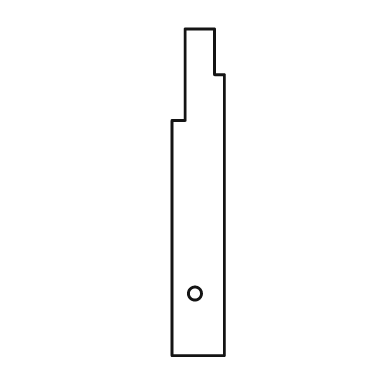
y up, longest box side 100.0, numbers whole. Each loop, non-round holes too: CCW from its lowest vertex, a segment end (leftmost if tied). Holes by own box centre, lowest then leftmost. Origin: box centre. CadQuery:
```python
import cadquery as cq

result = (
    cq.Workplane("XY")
    .moveTo(-8.0, -50.0)
    .lineTo(8.0, -50.0)
    .lineTo(8.0, 36.0)
    .lineTo(5.0, 36.0)
    .lineTo(5.0, 50.0)
    .lineTo(-4.0, 50.0)
    .lineTo(-4.0, 22.0)
    .lineTo(-8.0, 22.0)
    .close()
    .moveTo(-1.0, -31.0)
    .circle(2.0)
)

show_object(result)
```